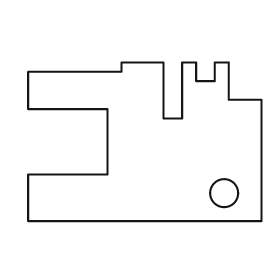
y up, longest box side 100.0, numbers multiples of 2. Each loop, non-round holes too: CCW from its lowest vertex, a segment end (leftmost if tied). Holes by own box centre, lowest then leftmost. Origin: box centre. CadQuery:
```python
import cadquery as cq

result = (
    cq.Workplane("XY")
    .moveTo(-50.0, -34.0)
    .lineTo(50.0, -34.0)
    .lineTo(50.0, 18.0)
    .lineTo(36.0, 18.0)
    .lineTo(36.0, 34.0)
    .lineTo(30.0, 34.0)
    .lineTo(30.0, 26.0)
    .lineTo(22.0, 26.0)
    .lineTo(22.0, 34.0)
    .lineTo(16.0, 34.0)
    .lineTo(16.0, 10.0)
    .lineTo(8.0, 10.0)
    .lineTo(8.0, 34.0)
    .lineTo(-10.0, 34.0)
    .lineTo(-10.0, 30.0)
    .lineTo(-50.0, 30.0)
    .lineTo(-50.0, 14.0)
    .lineTo(-16.0, 14.0)
    .lineTo(-16.0, -14.0)
    .lineTo(-50.0, -14.0)
    .close()
    .moveTo(34.0, -22.0)
    .circle(6.0)
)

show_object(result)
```